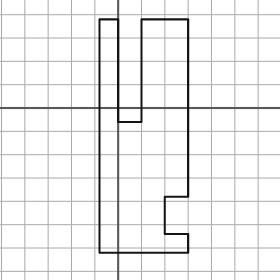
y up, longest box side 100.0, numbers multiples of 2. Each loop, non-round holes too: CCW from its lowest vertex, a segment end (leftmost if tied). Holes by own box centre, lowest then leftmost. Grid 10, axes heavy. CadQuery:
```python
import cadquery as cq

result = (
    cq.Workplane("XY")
    .moveTo(-8.0, -62.0)
    .lineTo(30.0, -62.0)
    .lineTo(30.0, -54.0)
    .lineTo(20.0, -54.0)
    .lineTo(20.0, -38.0)
    .lineTo(30.0, -38.0)
    .lineTo(30.0, 38.0)
    .lineTo(10.0, 38.0)
    .lineTo(10.0, -6.0)
    .lineTo(0.0, -6.0)
    .lineTo(0.0, 38.0)
    .lineTo(-8.0, 38.0)
    .close()
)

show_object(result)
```